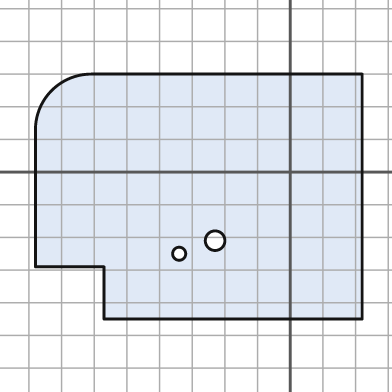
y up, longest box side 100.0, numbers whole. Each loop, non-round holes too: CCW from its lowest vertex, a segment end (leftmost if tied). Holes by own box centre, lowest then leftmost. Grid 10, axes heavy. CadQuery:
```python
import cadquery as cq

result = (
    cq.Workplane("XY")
    .moveTo(-57.0, -45.0)
    .lineTo(22.0, -45.0)
    .lineTo(22.0, 30.0)
    .lineTo(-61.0, 30.0)
    .threePointArc((-73.0, 25.0), (-78.0, 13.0))
    .lineTo(-78.0, -29.0)
    .lineTo(-57.0, -29.0)
    .close()
    .moveTo(-34.0, -25.0)
    .circle(2.0)
    .moveTo(-23.0, -21.0)
    .circle(3.0)
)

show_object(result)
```